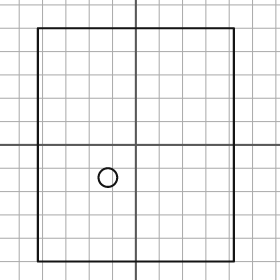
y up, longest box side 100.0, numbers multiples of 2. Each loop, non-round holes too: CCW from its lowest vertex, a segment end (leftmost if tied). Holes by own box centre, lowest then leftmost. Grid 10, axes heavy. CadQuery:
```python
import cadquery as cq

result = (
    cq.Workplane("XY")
    .moveTo(-42.0, -50.0)
    .lineTo(42.0, -50.0)
    .lineTo(42.0, 50.0)
    .lineTo(-42.0, 50.0)
    .close()
    .moveTo(-12.0, -14.0)
    .circle(4.0)
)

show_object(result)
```